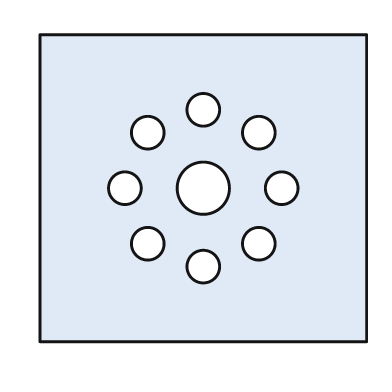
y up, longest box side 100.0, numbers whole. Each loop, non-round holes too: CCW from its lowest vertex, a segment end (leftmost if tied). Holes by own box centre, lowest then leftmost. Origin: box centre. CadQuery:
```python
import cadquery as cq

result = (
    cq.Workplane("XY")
    .moveTo(-50.0, -47.0)
    .lineTo(50.0, -47.0)
    .lineTo(50.0, 47.0)
    .lineTo(-50.0, 47.0)
    .close()
    .moveTo(0.0, -24.0)
    .circle(5.0)
    .moveTo(-17.0, -17.0)
    .circle(5.0)
    .moveTo(17.0, -17.0)
    .circle(5.0)
    .moveTo(-24.0, 0.0)
    .circle(5.0)
    .moveTo(0.0, 0.0)
    .circle(8.0)
    .moveTo(24.0, 0.0)
    .circle(5.0)
    .moveTo(-17.0, 17.0)
    .circle(5.0)
    .moveTo(17.0, 17.0)
    .circle(5.0)
    .moveTo(0.0, 24.0)
    .circle(5.0)
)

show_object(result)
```